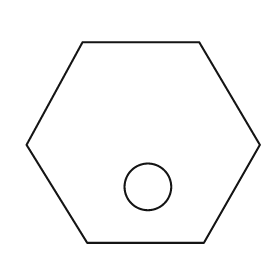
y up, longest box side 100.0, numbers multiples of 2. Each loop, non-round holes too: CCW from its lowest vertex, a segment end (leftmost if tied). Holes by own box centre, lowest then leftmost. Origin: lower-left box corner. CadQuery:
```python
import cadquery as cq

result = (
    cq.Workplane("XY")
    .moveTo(26.0, 0.0)
    .lineTo(76.0, 0.0)
    .lineTo(100.0, 42.0)
    .lineTo(74.0, 86.0)
    .lineTo(24.0, 86.0)
    .lineTo(0.0, 42.0)
    .close()
    .moveTo(52.0, 24.0)
    .circle(10.0)
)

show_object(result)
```